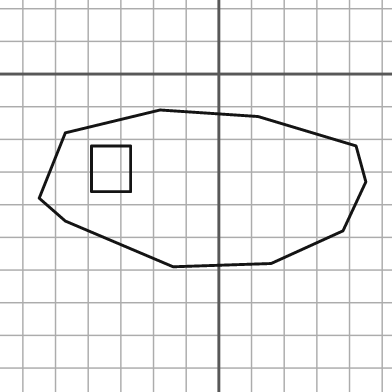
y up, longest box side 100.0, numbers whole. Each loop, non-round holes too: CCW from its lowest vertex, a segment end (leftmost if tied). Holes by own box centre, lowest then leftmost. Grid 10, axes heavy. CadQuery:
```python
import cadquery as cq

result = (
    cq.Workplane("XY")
    .moveTo(-14.0, -59.0)
    .lineTo(16.0, -58.0)
    .lineTo(38.0, -48.0)
    .lineTo(45.0, -33.0)
    .lineTo(42.0, -22.0)
    .lineTo(12.0, -13.0)
    .lineTo(-18.0, -11.0)
    .lineTo(-47.0, -18.0)
    .lineTo(-55.0, -38.0)
    .lineTo(-47.0, -45.0)
    .close()
    .moveTo(-39.0, -36.0)
    .lineTo(-27.0, -36.0)
    .lineTo(-27.0, -22.0)
    .lineTo(-39.0, -22.0)
    .close()
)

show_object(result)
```